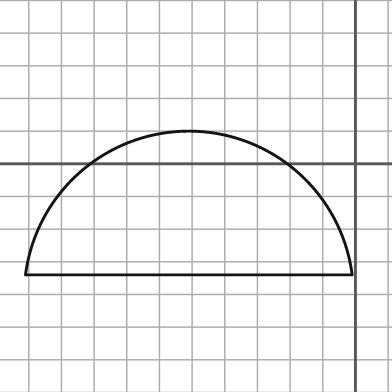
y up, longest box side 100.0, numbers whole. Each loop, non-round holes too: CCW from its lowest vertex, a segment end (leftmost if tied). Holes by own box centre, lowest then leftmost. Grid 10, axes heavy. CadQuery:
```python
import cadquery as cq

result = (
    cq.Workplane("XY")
    .moveTo(-101.0, -34.0)
    .lineTo(-1.0, -34.0)
    .threePointArc((-51.0, 10.0), (-101.0, -34.0))
    .close()
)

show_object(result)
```